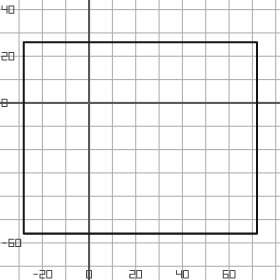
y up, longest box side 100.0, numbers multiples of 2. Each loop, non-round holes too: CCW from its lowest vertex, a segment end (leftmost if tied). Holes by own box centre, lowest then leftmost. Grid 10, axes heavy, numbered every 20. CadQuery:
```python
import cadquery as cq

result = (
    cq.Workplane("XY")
    .moveTo(-28.0, -56.0)
    .lineTo(72.0, -56.0)
    .lineTo(72.0, 26.0)
    .lineTo(-28.0, 26.0)
    .close()
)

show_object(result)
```